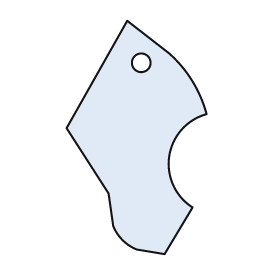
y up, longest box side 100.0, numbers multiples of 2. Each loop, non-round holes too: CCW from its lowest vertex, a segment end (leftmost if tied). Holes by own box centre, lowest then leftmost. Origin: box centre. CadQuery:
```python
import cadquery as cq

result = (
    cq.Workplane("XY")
    .moveTo(12.0, -50.0)
    .lineTo(24.0, -30.0)
    .threePointArc((14.0, -8.0), (30.0, 10.0))
    .threePointArc((24.0, 24.0), (14.0, 36.0))
    .lineTo(-4.0, 50.0)
    .lineTo(-30.0, 4.0)
    .lineTo(-12.0, -24.0)
    .lineTo(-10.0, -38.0)
    .threePointArc((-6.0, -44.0), (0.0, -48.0))
    .close()
    .moveTo(2.0, 32.0)
    .circle(4.0)
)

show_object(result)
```